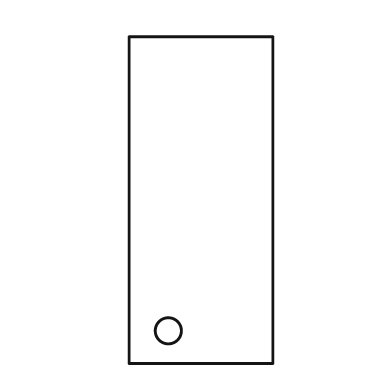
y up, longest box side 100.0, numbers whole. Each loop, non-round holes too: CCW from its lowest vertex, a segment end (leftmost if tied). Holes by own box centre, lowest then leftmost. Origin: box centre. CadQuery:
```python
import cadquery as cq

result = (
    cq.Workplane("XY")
    .moveTo(-22.0, -50.0)
    .lineTo(22.0, -50.0)
    .lineTo(22.0, 50.0)
    .lineTo(-22.0, 50.0)
    .close()
    .moveTo(-10.0, -40.0)
    .circle(4.0)
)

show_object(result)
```